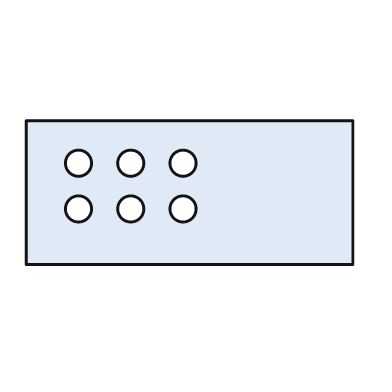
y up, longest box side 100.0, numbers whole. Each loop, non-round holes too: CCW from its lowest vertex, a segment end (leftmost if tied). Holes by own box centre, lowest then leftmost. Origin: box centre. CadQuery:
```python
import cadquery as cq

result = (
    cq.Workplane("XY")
    .moveTo(-50.0, -22.0)
    .lineTo(50.0, -22.0)
    .lineTo(50.0, 22.0)
    .lineTo(-50.0, 22.0)
    .close()
    .moveTo(-34.0, -5.0)
    .circle(4.0)
    .moveTo(-18.0, -5.0)
    .circle(4.0)
    .moveTo(-2.0, -5.0)
    .circle(4.0)
    .moveTo(-34.0, 9.0)
    .circle(4.0)
    .moveTo(-18.0, 9.0)
    .circle(4.0)
    .moveTo(-2.0, 9.0)
    .circle(4.0)
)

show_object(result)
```